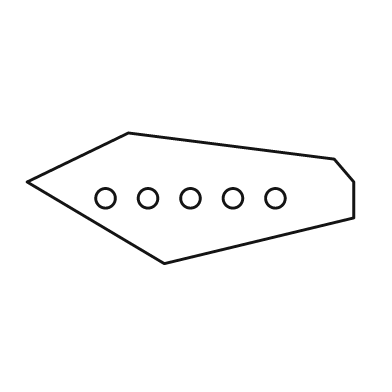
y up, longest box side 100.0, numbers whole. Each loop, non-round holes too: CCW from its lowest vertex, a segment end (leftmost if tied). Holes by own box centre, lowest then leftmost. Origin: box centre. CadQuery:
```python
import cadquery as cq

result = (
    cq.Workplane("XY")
    .moveTo(-8.0, -20.0)
    .lineTo(50.0, -6.0)
    .lineTo(50.0, 5.0)
    .lineTo(44.0, 12.0)
    .lineTo(-19.0, 20.0)
    .lineTo(-50.0, 5.0)
    .close()
    .moveTo(-26.0, 0.0)
    .circle(3.0)
    .moveTo(-13.0, 0.0)
    .circle(3.0)
    .moveTo(0.0, 0.0)
    .circle(3.0)
    .moveTo(13.0, 0.0)
    .circle(3.0)
    .moveTo(26.0, 0.0)
    .circle(3.0)
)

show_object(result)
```